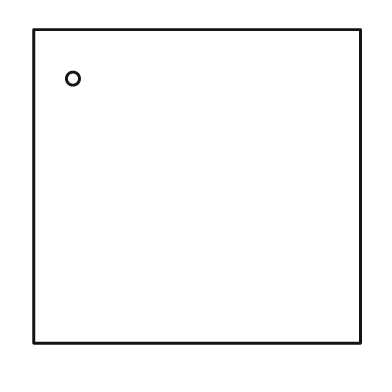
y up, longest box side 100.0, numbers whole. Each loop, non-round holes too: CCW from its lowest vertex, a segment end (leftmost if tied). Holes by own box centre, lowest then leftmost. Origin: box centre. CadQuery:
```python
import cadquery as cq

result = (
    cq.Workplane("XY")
    .moveTo(-50.0, -48.0)
    .lineTo(50.0, -48.0)
    .lineTo(50.0, 48.0)
    .lineTo(-50.0, 48.0)
    .close()
    .moveTo(-38.0, 33.0)
    .circle(2.0)
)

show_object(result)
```